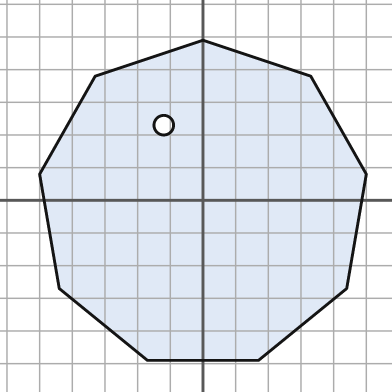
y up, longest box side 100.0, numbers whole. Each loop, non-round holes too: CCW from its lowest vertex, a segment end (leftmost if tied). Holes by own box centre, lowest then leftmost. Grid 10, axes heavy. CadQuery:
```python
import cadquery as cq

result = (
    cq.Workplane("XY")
    .moveTo(-17.0, -49.0)
    .lineTo(17.0, -49.0)
    .lineTo(44.0, -27.0)
    .lineTo(50.0, 8.0)
    .lineTo(33.0, 38.0)
    .lineTo(0.0, 49.0)
    .lineTo(-33.0, 38.0)
    .lineTo(-50.0, 8.0)
    .lineTo(-44.0, -27.0)
    .close()
    .moveTo(-12.0, 23.0)
    .circle(3.0)
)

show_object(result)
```